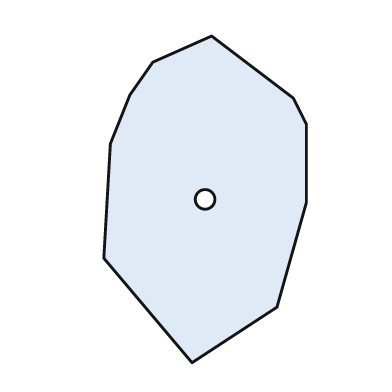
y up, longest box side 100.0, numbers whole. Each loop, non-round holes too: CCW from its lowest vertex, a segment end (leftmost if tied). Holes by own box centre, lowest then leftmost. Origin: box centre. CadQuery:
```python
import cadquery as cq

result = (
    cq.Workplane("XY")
    .moveTo(-4.0, -50.0)
    .lineTo(22.0, -33.0)
    .lineTo(31.0, -1.0)
    .lineTo(31.0, 23.0)
    .lineTo(27.0, 31.0)
    .lineTo(2.0, 50.0)
    .lineTo(-16.0, 42.0)
    .lineTo(-23.0, 32.0)
    .lineTo(-29.0, 17.0)
    .lineTo(-31.0, -18.0)
    .close()
    .moveTo(0.0, 0.0)
    .circle(3.0)
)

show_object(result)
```